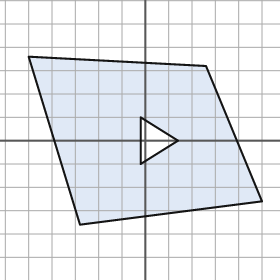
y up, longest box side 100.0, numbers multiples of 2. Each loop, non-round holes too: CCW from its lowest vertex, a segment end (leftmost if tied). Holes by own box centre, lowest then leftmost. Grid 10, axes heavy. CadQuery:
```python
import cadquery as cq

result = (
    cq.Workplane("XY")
    .moveTo(-28.0, -36.0)
    .lineTo(50.0, -26.0)
    .lineTo(26.0, 32.0)
    .lineTo(-50.0, 36.0)
    .close()
    .moveTo(-2.0, -10.0)
    .lineTo(14.0, 0.0)
    .lineTo(-2.0, 10.0)
    .close()
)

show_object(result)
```